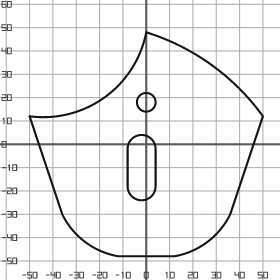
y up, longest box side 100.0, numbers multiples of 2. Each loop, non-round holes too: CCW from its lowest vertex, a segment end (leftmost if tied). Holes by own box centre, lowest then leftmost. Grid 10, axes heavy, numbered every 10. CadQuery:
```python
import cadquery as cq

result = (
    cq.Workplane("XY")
    .moveTo(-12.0, -48.0)
    .lineTo(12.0, -48.0)
    .threePointArc((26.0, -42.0), (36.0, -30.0))
    .lineTo(50.0, 12.0)
    .threePointArc((28.0, 34.0), (0.0, 48.0))
    .threePointArc((-18.0, 20.0), (-50.0, 12.0))
    .lineTo(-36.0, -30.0)
    .threePointArc((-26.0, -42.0), (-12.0, -48.0))
    .close()
    .moveTo(-8.0, -18.0)
    .threePointArc((-2.0, -24.0), (4.0, -18.0))
    .lineTo(4.0, -2.0)
    .threePointArc((-2.0, 4.0), (-8.0, -2.0))
    .close()
    .moveTo(0.0, 18.0)
    .circle(4.0)
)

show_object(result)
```